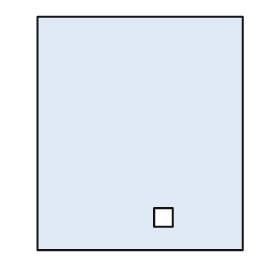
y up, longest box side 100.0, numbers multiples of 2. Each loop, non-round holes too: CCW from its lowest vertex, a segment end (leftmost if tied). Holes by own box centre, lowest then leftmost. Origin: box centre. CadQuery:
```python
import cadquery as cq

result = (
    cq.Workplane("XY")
    .moveTo(-44.0, -50.0)
    .lineTo(44.0, -50.0)
    .lineTo(44.0, 50.0)
    .lineTo(-44.0, 50.0)
    .close()
    .moveTo(6.0, -40.0)
    .lineTo(14.0, -40.0)
    .lineTo(14.0, -32.0)
    .lineTo(6.0, -32.0)
    .close()
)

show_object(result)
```